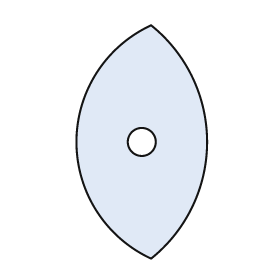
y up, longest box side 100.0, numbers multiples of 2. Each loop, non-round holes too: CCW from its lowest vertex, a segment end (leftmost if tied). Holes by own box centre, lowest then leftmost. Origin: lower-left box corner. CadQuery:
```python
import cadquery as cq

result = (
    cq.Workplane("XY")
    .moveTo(32.0, 0.0)
    .threePointArc((56.0, 50.0), (32.0, 100.0))
    .threePointArc((0.0, 50.0), (32.0, 0.0))
    .close()
    .moveTo(28.0, 50.0)
    .circle(6.0)
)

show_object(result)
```